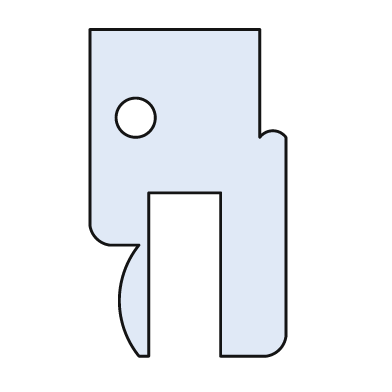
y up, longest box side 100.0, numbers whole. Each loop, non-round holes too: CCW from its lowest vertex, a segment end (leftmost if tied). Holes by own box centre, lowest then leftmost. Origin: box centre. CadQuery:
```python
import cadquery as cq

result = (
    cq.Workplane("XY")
    .moveTo(-15.0, -50.0)
    .lineTo(-12.0, -50.0)
    .lineTo(-12.0, 0.0)
    .lineTo(10.0, 0.0)
    .lineTo(10.0, -50.0)
    .lineTo(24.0, -50.0)
    .threePointArc((28.0, -48.0), (30.0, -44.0))
    .lineTo(30.0, 17.0)
    .threePointArc((26.0, 19.0), (22.0, 17.0))
    .lineTo(22.0, 50.0)
    .lineTo(-30.0, 50.0)
    .lineTo(-30.0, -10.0)
    .threePointArc((-28.0, -14.0), (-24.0, -16.0))
    .lineTo(-15.0, -16.0)
    .threePointArc((-21.0, -33.0), (-15.0, -50.0))
    .close()
    .moveTo(-16.0, 23.0)
    .circle(6.0)
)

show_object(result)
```